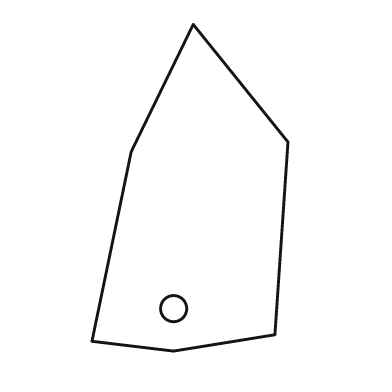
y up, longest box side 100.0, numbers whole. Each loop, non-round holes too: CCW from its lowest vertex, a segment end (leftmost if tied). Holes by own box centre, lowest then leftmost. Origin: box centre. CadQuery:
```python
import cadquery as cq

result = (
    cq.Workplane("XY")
    .moveTo(-5.0, -50.0)
    .lineTo(26.0, -45.0)
    .lineTo(30.0, 14.0)
    .lineTo(1.0, 50.0)
    .lineTo(-18.0, 11.0)
    .lineTo(-30.0, -47.0)
    .close()
    .moveTo(-5.0, -37.0)
    .circle(4.0)
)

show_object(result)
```